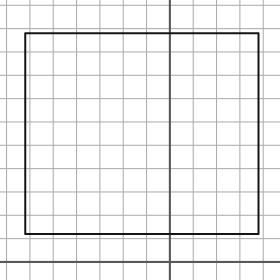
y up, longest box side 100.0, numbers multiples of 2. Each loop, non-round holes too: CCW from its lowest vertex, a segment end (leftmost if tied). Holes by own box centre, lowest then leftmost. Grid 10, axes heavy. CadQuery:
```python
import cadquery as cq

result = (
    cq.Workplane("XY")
    .moveTo(-62.0, 12.0)
    .lineTo(38.0, 12.0)
    .lineTo(38.0, 98.0)
    .lineTo(-62.0, 98.0)
    .close()
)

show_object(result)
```